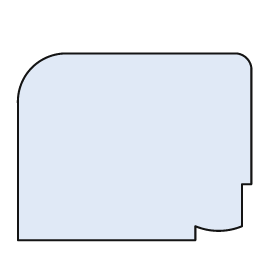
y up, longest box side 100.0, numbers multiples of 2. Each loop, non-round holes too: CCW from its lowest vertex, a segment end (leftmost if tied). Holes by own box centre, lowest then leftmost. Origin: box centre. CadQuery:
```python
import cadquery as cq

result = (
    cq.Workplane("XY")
    .moveTo(-50.0, -40.0)
    .lineTo(26.0, -40.0)
    .lineTo(26.0, -34.0)
    .threePointArc((36.0, -36.0), (46.0, -34.0))
    .lineTo(46.0, -16.0)
    .lineTo(50.0, -16.0)
    .lineTo(50.0, 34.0)
    .threePointArc((48.0, 38.0), (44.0, 40.0))
    .lineTo(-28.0, 40.0)
    .threePointArc((-44.0, 34.0), (-50.0, 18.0))
    .close()
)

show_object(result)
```